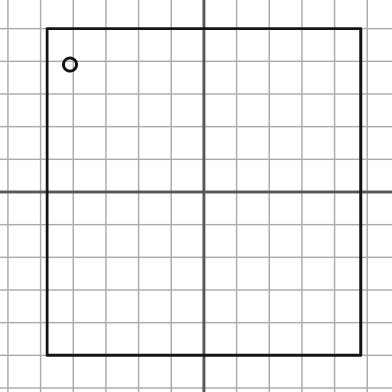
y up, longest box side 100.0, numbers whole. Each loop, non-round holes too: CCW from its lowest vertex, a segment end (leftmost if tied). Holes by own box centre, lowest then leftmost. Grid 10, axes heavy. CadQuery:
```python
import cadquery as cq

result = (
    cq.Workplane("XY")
    .moveTo(-48.0, -50.0)
    .lineTo(48.0, -50.0)
    .lineTo(48.0, 50.0)
    .lineTo(-48.0, 50.0)
    .close()
    .moveTo(-41.0, 39.0)
    .circle(2.0)
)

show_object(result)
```